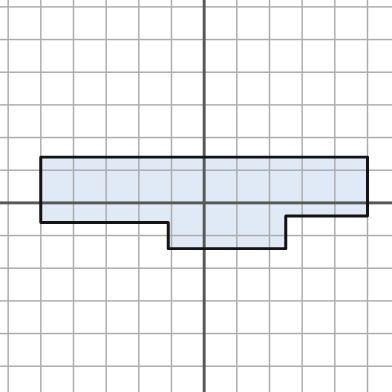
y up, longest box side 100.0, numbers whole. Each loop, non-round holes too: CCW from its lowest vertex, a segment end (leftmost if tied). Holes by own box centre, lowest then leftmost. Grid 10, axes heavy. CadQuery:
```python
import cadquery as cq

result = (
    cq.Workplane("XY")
    .moveTo(-11.0, -14.0)
    .lineTo(25.0, -14.0)
    .lineTo(25.0, -4.0)
    .lineTo(50.0, -4.0)
    .lineTo(50.0, 14.0)
    .lineTo(-50.0, 14.0)
    .lineTo(-50.0, -6.0)
    .lineTo(-11.0, -6.0)
    .close()
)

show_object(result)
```